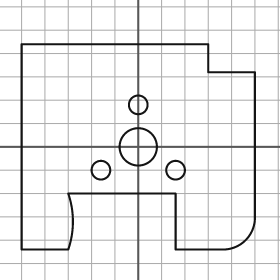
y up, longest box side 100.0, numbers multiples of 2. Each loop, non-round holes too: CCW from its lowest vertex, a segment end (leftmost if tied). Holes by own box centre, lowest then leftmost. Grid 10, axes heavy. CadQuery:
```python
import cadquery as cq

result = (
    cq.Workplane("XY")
    .moveTo(-50.0, -44.0)
    .lineTo(-30.0, -44.0)
    .threePointArc((-28.0, -32.0), (-30.0, -20.0))
    .lineTo(16.0, -20.0)
    .lineTo(16.0, -44.0)
    .lineTo(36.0, -44.0)
    .threePointArc((46.0, -40.0), (50.0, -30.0))
    .lineTo(50.0, 32.0)
    .lineTo(30.0, 32.0)
    .lineTo(30.0, 44.0)
    .lineTo(-50.0, 44.0)
    .close()
    .moveTo(-16.0, -10.0)
    .circle(4.0)
    .moveTo(16.0, -10.0)
    .circle(4.0)
    .moveTo(0.0, 0.0)
    .circle(8.0)
    .moveTo(0.0, 18.0)
    .circle(4.0)
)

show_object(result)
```